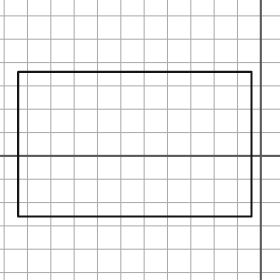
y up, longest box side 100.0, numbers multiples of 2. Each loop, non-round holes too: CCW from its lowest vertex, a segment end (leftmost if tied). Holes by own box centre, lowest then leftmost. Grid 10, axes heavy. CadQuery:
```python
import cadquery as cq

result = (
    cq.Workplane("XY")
    .moveTo(-104.0, -26.0)
    .lineTo(-4.0, -26.0)
    .lineTo(-4.0, 36.0)
    .lineTo(-104.0, 36.0)
    .close()
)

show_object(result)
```